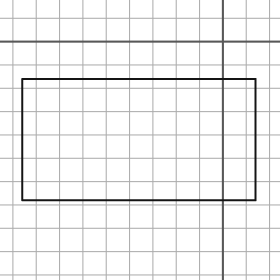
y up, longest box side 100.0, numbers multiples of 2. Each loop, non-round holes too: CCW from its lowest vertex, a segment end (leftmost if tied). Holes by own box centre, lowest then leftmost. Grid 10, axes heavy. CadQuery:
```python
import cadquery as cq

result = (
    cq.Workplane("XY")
    .moveTo(-86.0, -68.0)
    .lineTo(14.0, -68.0)
    .lineTo(14.0, -16.0)
    .lineTo(-86.0, -16.0)
    .close()
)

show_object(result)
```